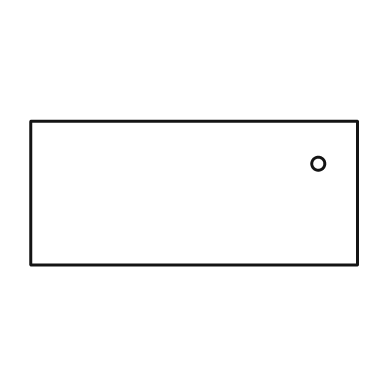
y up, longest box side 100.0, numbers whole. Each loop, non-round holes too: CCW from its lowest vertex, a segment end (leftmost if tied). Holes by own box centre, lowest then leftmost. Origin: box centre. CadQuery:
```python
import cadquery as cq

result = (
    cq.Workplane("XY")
    .moveTo(-50.0, -22.0)
    .lineTo(50.0, -22.0)
    .lineTo(50.0, 22.0)
    .lineTo(-50.0, 22.0)
    .close()
    .moveTo(38.0, 9.0)
    .circle(2.0)
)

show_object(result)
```